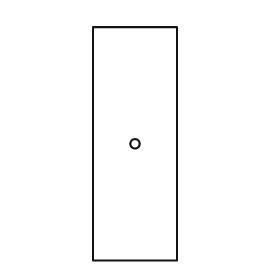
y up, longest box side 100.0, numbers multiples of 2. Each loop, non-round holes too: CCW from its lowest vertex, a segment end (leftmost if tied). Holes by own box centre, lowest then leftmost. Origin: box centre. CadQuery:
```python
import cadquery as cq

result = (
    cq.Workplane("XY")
    .moveTo(-18.0, -50.0)
    .lineTo(18.0, -50.0)
    .lineTo(18.0, 50.0)
    .lineTo(-18.0, 50.0)
    .close()
    .moveTo(0.0, 0.0)
    .circle(2.0)
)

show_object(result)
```